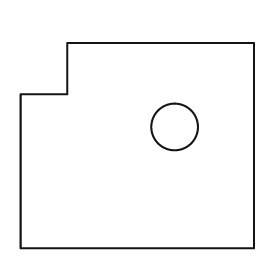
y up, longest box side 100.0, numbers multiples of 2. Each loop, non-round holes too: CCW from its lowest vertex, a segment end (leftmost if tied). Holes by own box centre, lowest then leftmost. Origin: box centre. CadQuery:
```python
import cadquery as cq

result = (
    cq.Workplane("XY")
    .moveTo(-50.0, -44.0)
    .lineTo(50.0, -44.0)
    .lineTo(50.0, 44.0)
    .lineTo(-30.0, 44.0)
    .lineTo(-30.0, 22.0)
    .lineTo(-50.0, 22.0)
    .close()
    .moveTo(16.0, 8.0)
    .circle(10.0)
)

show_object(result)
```